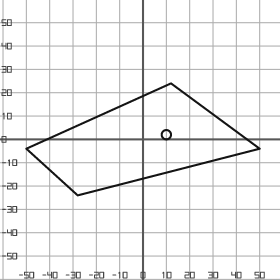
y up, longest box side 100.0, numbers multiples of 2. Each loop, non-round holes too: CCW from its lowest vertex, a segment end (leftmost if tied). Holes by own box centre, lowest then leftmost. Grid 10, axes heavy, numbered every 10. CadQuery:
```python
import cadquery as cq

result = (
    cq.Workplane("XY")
    .moveTo(-28.0, -24.0)
    .lineTo(50.0, -4.0)
    .lineTo(12.0, 24.0)
    .lineTo(-50.0, -4.0)
    .close()
    .moveTo(10.0, 2.0)
    .circle(2.0)
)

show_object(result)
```